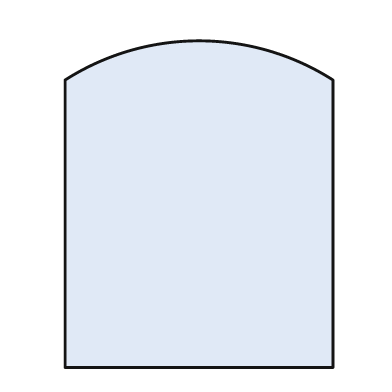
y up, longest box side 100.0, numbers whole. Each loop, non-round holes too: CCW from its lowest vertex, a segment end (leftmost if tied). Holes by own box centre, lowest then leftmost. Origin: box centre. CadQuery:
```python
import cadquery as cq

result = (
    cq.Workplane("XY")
    .moveTo(-41.0, -50.0)
    .lineTo(41.0, -50.0)
    .lineTo(41.0, 38.0)
    .threePointArc((0.0, 50.0), (-41.0, 38.0))
    .close()
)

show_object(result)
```